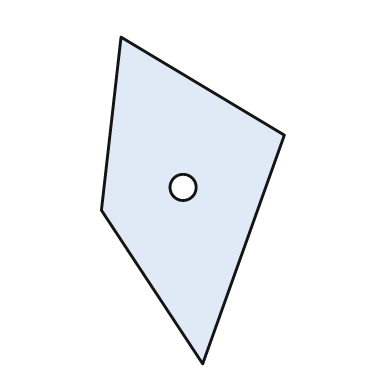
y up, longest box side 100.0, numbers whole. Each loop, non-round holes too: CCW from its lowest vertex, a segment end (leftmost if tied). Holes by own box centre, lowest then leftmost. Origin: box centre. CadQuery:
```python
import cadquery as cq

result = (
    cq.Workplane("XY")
    .moveTo(3.0, -50.0)
    .lineTo(28.0, 20.0)
    .lineTo(-22.0, 50.0)
    .lineTo(-28.0, -3.0)
    .close()
    .moveTo(-3.0, 4.0)
    .circle(4.0)
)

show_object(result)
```